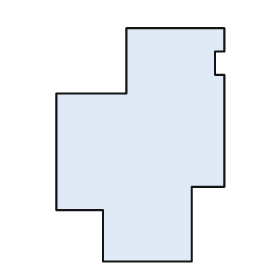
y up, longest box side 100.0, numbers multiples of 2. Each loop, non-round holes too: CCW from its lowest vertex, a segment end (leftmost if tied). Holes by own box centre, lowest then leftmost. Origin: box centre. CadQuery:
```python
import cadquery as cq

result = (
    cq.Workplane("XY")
    .moveTo(-16.0, -50.0)
    .lineTo(22.0, -50.0)
    .lineTo(22.0, -18.0)
    .lineTo(36.0, -18.0)
    .lineTo(36.0, 30.0)
    .lineTo(32.0, 30.0)
    .lineTo(32.0, 40.0)
    .lineTo(36.0, 40.0)
    .lineTo(36.0, 50.0)
    .lineTo(-6.0, 50.0)
    .lineTo(-6.0, 22.0)
    .lineTo(-36.0, 22.0)
    .lineTo(-36.0, -28.0)
    .lineTo(-16.0, -28.0)
    .close()
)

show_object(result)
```